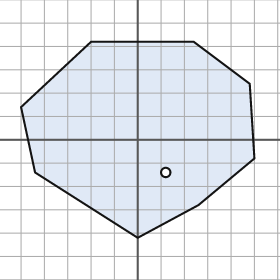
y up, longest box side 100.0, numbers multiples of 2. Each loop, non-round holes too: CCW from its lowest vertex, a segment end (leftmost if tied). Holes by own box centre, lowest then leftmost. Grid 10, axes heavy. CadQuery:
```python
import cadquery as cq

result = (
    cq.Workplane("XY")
    .moveTo(0.0, -42.0)
    .lineTo(26.0, -28.0)
    .lineTo(50.0, -8.0)
    .lineTo(48.0, 24.0)
    .lineTo(24.0, 42.0)
    .lineTo(-20.0, 42.0)
    .lineTo(-50.0, 14.0)
    .lineTo(-44.0, -14.0)
    .close()
    .moveTo(12.0, -14.0)
    .circle(2.0)
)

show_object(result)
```